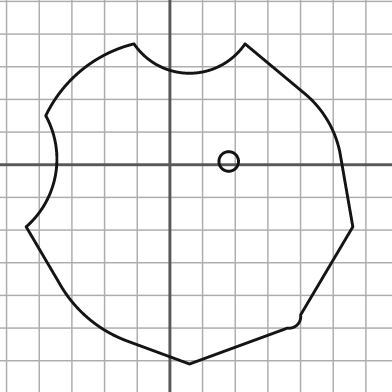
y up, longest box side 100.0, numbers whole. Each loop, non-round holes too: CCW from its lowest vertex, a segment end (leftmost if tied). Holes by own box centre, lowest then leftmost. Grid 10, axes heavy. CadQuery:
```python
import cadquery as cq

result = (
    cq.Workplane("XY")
    .moveTo(6.0, -61.0)
    .lineTo(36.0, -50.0)
    .threePointArc((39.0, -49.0), (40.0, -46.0))
    .lineTo(56.0, -19.0)
    .lineTo(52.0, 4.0)
    .threePointArc((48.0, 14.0), (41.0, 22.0))
    .lineTo(23.0, 37.0)
    .threePointArc((6.0, 28.0), (-11.0, 37.0))
    .threePointArc((-27.0, 29.0), (-38.0, 15.0))
    .threePointArc((-35.0, -3.0), (-44.0, -19.0))
    .lineTo(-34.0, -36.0)
    .threePointArc((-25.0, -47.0), (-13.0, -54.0))
    .close()
    .moveTo(18.0, 1.0)
    .circle(3.0)
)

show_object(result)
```